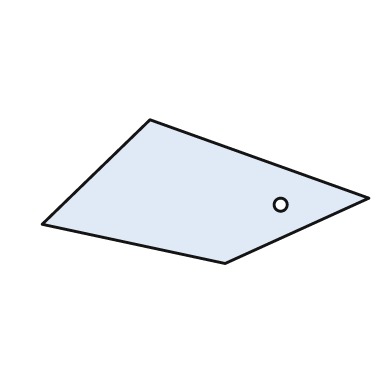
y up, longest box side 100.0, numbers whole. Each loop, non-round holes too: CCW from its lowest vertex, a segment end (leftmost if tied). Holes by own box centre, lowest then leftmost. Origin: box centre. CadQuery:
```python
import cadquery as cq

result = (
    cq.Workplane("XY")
    .moveTo(6.0, -22.0)
    .lineTo(50.0, -2.0)
    .lineTo(-17.0, 22.0)
    .lineTo(-50.0, -10.0)
    .close()
    .moveTo(23.0, -4.0)
    .circle(2.0)
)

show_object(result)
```